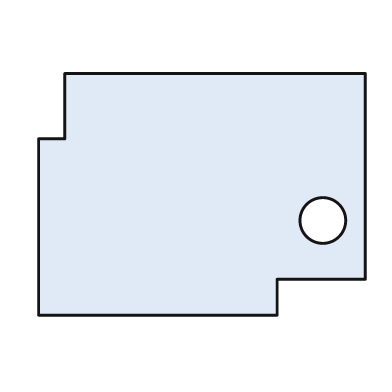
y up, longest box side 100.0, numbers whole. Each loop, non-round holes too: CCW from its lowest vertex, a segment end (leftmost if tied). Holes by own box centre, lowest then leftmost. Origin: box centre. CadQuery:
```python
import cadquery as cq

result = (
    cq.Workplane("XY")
    .moveTo(-50.0, -37.0)
    .lineTo(23.0, -37.0)
    .lineTo(23.0, -26.0)
    .lineTo(50.0, -26.0)
    .lineTo(50.0, 37.0)
    .lineTo(-42.0, 37.0)
    .lineTo(-42.0, 17.0)
    .lineTo(-50.0, 17.0)
    .close()
    .moveTo(37.0, -8.0)
    .circle(7.0)
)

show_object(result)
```